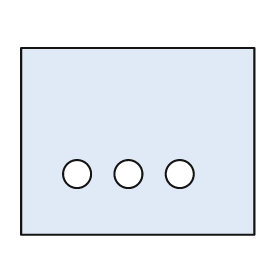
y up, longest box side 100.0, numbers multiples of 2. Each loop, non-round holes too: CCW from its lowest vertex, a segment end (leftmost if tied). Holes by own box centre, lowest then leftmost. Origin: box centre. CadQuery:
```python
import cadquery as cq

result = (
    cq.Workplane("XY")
    .moveTo(-50.0, -40.0)
    .lineTo(50.0, -40.0)
    .lineTo(50.0, 40.0)
    .lineTo(-50.0, 40.0)
    .close()
    .moveTo(-26.0, -14.0)
    .circle(6.0)
    .moveTo(-4.0, -14.0)
    .circle(6.0)
    .moveTo(18.0, -14.0)
    .circle(6.0)
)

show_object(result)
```